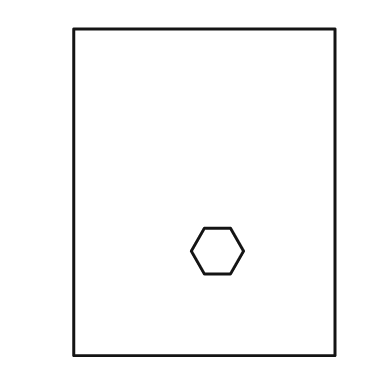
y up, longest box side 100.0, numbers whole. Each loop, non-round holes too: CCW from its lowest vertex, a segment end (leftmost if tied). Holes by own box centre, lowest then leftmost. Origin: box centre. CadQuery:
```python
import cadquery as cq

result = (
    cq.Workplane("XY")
    .moveTo(-40.0, -50.0)
    .lineTo(40.0, -50.0)
    .lineTo(40.0, 50.0)
    .lineTo(-40.0, 50.0)
    .close()
    .moveTo(0.0, -25.0)
    .lineTo(8.0, -25.0)
    .lineTo(12.0, -18.0)
    .lineTo(8.0, -11.0)
    .lineTo(0.0, -11.0)
    .lineTo(-4.0, -18.0)
    .close()
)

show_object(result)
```